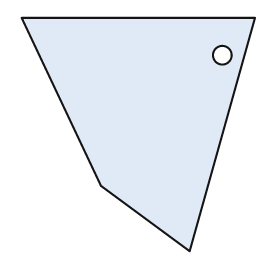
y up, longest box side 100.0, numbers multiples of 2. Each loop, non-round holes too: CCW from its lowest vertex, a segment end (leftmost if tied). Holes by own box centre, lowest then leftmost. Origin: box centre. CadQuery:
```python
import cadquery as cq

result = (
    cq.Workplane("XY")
    .moveTo(22.0, -50.0)
    .lineTo(50.0, 50.0)
    .lineTo(-50.0, 50.0)
    .lineTo(-16.0, -22.0)
    .close()
    .moveTo(36.0, 34.0)
    .circle(4.0)
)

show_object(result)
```